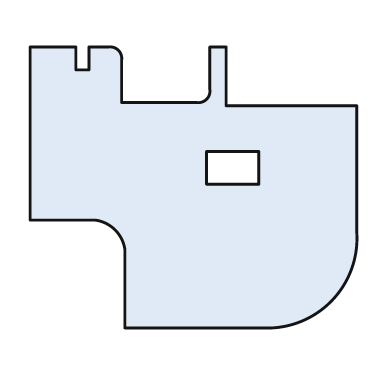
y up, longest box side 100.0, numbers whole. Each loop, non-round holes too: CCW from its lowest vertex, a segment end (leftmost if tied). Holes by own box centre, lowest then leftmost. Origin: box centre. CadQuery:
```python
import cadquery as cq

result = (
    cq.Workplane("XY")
    .moveTo(-21.0, -43.0)
    .lineTo(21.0, -43.0)
    .threePointArc((42.0, -35.0), (50.0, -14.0))
    .lineTo(50.0, 25.0)
    .lineTo(10.0, 25.0)
    .lineTo(10.0, 43.0)
    .lineTo(5.0, 43.0)
    .lineTo(5.0, 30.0)
    .threePointArc((4.0, 27.0), (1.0, 26.0))
    .lineTo(-22.0, 26.0)
    .lineTo(-22.0, 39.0)
    .threePointArc((-23.0, 42.0), (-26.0, 43.0))
    .lineTo(-32.0, 43.0)
    .lineTo(-32.0, 36.0)
    .lineTo(-36.0, 36.0)
    .lineTo(-36.0, 43.0)
    .lineTo(-50.0, 43.0)
    .lineTo(-50.0, -10.0)
    .lineTo(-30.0, -10.0)
    .threePointArc((-24.0, -13.0), (-21.0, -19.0))
    .close()
    .moveTo(4.0, 1.0)
    .lineTo(20.0, 1.0)
    .lineTo(20.0, 11.0)
    .lineTo(4.0, 11.0)
    .close()
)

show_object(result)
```